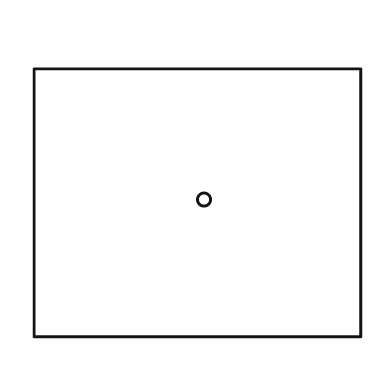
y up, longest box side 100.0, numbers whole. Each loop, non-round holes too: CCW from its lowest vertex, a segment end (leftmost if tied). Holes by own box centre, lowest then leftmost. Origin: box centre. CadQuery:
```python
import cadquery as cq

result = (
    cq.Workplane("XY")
    .moveTo(-50.0, -41.0)
    .lineTo(50.0, -41.0)
    .lineTo(50.0, 41.0)
    .lineTo(-50.0, 41.0)
    .close()
    .moveTo(2.0, 1.0)
    .circle(2.0)
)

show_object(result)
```